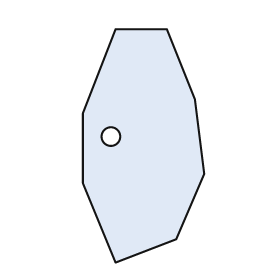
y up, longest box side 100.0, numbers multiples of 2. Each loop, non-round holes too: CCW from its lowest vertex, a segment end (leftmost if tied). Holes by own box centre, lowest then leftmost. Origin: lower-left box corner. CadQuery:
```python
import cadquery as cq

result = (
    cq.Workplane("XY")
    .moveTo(14.0, 0.0)
    .lineTo(40.0, 10.0)
    .lineTo(52.0, 38.0)
    .lineTo(48.0, 70.0)
    .lineTo(36.0, 100.0)
    .lineTo(14.0, 100.0)
    .lineTo(0.0, 64.0)
    .lineTo(0.0, 34.0)
    .close()
    .moveTo(12.0, 54.0)
    .circle(4.0)
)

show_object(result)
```